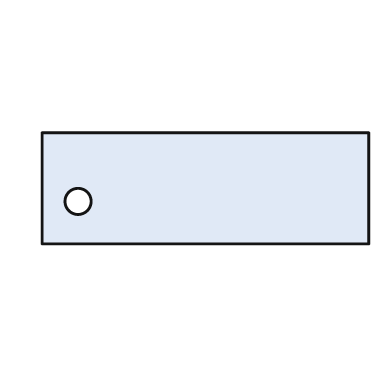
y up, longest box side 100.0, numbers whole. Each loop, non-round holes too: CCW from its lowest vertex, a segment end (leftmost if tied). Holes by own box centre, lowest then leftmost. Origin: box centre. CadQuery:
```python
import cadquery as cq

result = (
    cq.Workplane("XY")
    .moveTo(-50.0, -17.0)
    .lineTo(50.0, -17.0)
    .lineTo(50.0, 17.0)
    .lineTo(-50.0, 17.0)
    .close()
    .moveTo(-39.0, -4.0)
    .circle(4.0)
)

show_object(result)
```